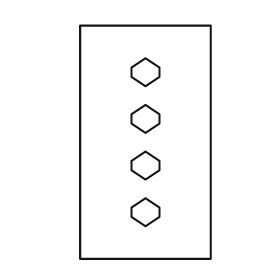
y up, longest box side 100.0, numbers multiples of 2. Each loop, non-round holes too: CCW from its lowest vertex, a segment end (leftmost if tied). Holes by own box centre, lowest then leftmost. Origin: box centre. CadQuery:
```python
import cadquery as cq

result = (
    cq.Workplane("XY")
    .moveTo(-28.0, -50.0)
    .lineTo(28.0, -50.0)
    .lineTo(28.0, 50.0)
    .lineTo(-28.0, 50.0)
    .close()
    .moveTo(0.0, -36.0)
    .lineTo(6.0, -32.0)
    .lineTo(6.0, -28.0)
    .lineTo(0.0, -24.0)
    .lineTo(-6.0, -28.0)
    .lineTo(-6.0, -32.0)
    .close()
    .moveTo(0.0, -16.0)
    .lineTo(6.0, -12.0)
    .lineTo(6.0, -8.0)
    .lineTo(0.0, -4.0)
    .lineTo(-6.0, -8.0)
    .lineTo(-6.0, -12.0)
    .close()
    .moveTo(0.0, 4.0)
    .lineTo(6.0, 8.0)
    .lineTo(6.0, 12.0)
    .lineTo(0.0, 16.0)
    .lineTo(-6.0, 12.0)
    .lineTo(-6.0, 8.0)
    .close()
    .moveTo(0.0, 24.0)
    .lineTo(6.0, 28.0)
    .lineTo(6.0, 32.0)
    .lineTo(0.0, 36.0)
    .lineTo(-6.0, 32.0)
    .lineTo(-6.0, 28.0)
    .close()
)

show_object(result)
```